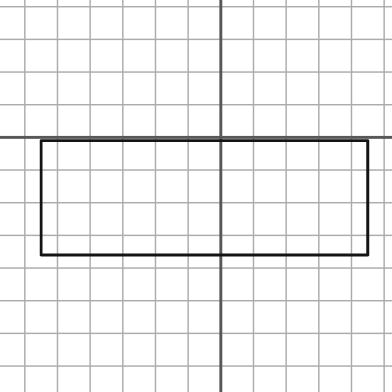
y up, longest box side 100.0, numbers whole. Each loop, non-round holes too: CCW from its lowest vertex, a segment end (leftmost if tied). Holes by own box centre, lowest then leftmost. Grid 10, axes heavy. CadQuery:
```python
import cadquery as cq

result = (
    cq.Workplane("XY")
    .moveTo(-55.0, -36.0)
    .lineTo(45.0, -36.0)
    .lineTo(45.0, -1.0)
    .lineTo(-55.0, -1.0)
    .close()
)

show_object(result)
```